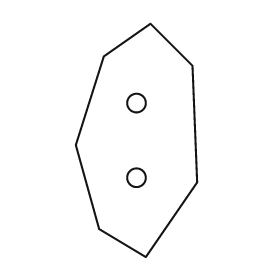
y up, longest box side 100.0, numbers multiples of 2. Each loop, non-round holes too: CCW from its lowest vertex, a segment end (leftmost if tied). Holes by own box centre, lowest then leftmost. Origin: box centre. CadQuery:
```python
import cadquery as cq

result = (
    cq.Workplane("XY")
    .moveTo(4.0, -50.0)
    .lineTo(26.0, -18.0)
    .lineTo(24.0, 32.0)
    .lineTo(6.0, 50.0)
    .lineTo(-14.0, 36.0)
    .lineTo(-26.0, -2.0)
    .lineTo(-16.0, -38.0)
    .close()
    .moveTo(0.0, -16.0)
    .circle(4.0)
    .moveTo(0.0, 16.0)
    .circle(4.0)
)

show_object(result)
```